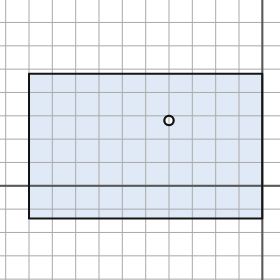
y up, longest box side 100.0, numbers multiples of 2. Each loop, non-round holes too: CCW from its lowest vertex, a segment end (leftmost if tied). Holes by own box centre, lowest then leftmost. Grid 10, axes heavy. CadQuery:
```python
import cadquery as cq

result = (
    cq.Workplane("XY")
    .moveTo(-100.0, -14.0)
    .lineTo(0.0, -14.0)
    .lineTo(0.0, 48.0)
    .lineTo(-100.0, 48.0)
    .close()
    .moveTo(-40.0, 28.0)
    .circle(2.0)
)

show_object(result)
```